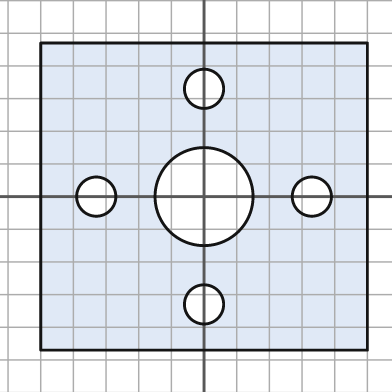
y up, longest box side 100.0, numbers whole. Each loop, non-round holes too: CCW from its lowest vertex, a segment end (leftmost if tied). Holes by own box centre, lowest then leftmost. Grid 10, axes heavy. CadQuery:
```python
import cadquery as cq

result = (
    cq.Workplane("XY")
    .moveTo(-50.0, -47.0)
    .lineTo(50.0, -47.0)
    .lineTo(50.0, 47.0)
    .lineTo(-50.0, 47.0)
    .close()
    .moveTo(0.0, -33.0)
    .circle(6.0)
    .moveTo(-33.0, 0.0)
    .circle(6.0)
    .moveTo(0.0, 0.0)
    .circle(15.0)
    .moveTo(33.0, 0.0)
    .circle(6.0)
    .moveTo(0.0, 33.0)
    .circle(6.0)
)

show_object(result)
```